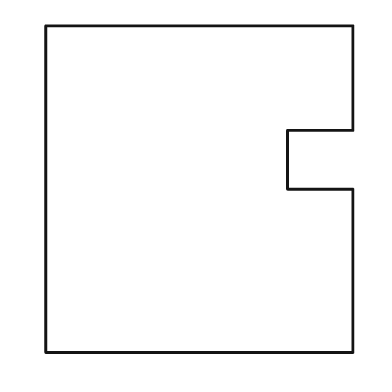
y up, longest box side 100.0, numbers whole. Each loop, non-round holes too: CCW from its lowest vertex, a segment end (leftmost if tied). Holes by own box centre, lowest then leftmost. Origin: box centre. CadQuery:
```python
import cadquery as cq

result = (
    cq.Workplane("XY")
    .moveTo(-47.0, -50.0)
    .lineTo(47.0, -50.0)
    .lineTo(47.0, 0.0)
    .lineTo(27.0, 0.0)
    .lineTo(27.0, 18.0)
    .lineTo(47.0, 18.0)
    .lineTo(47.0, 50.0)
    .lineTo(-47.0, 50.0)
    .close()
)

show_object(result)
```